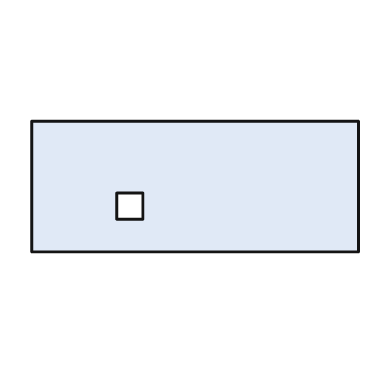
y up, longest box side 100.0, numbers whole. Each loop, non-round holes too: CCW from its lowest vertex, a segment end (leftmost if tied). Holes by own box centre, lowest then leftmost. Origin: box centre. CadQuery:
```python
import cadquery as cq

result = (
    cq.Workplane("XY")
    .moveTo(-50.0, -20.0)
    .lineTo(50.0, -20.0)
    .lineTo(50.0, 20.0)
    .lineTo(-50.0, 20.0)
    .close()
    .moveTo(-24.0, -10.0)
    .lineTo(-16.0, -10.0)
    .lineTo(-16.0, -2.0)
    .lineTo(-24.0, -2.0)
    .close()
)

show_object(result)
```